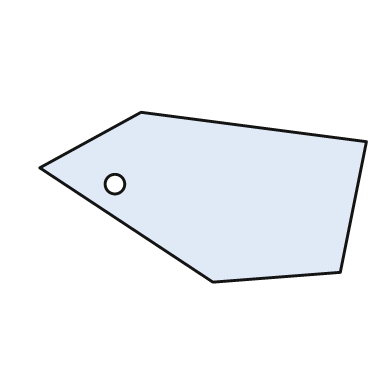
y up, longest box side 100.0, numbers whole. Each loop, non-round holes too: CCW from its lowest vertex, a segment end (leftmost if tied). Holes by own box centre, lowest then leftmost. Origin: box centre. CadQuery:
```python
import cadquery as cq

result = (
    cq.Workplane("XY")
    .moveTo(3.0, -26.0)
    .lineTo(42.0, -23.0)
    .lineTo(50.0, 17.0)
    .lineTo(-19.0, 26.0)
    .lineTo(-50.0, 9.0)
    .close()
    .moveTo(-27.0, 4.0)
    .circle(3.0)
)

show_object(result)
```